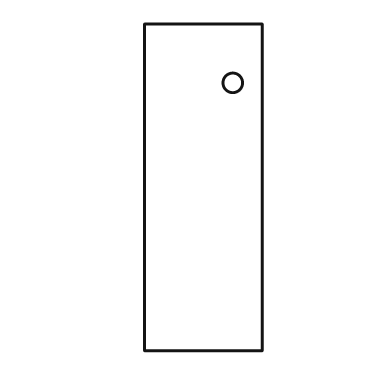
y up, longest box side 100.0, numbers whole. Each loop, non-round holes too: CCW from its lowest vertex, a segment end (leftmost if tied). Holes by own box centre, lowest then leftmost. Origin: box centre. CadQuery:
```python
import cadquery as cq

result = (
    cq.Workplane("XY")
    .moveTo(-18.0, -50.0)
    .lineTo(18.0, -50.0)
    .lineTo(18.0, 50.0)
    .lineTo(-18.0, 50.0)
    .close()
    .moveTo(9.0, 32.0)
    .circle(3.0)
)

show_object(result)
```